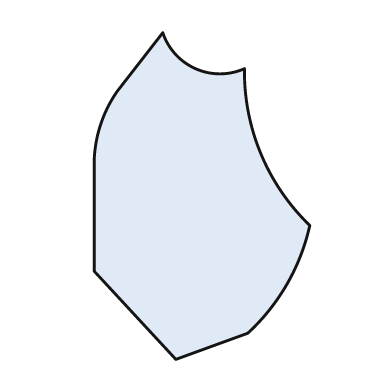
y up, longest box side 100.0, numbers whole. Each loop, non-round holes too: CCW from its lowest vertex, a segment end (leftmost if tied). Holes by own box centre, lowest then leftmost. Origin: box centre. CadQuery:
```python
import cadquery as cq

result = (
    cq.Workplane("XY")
    .moveTo(-8.0, -50.0)
    .lineTo(14.0, -42.0)
    .threePointArc((26.0, -27.0), (33.0, -9.0))
    .threePointArc((18.0, 13.0), (13.0, 39.0))
    .threePointArc((-2.0, 39.0), (-12.0, 50.0))
    .lineTo(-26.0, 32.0)
    .threePointArc((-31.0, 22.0), (-33.0, 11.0))
    .lineTo(-33.0, -23.0)
    .close()
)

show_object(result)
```